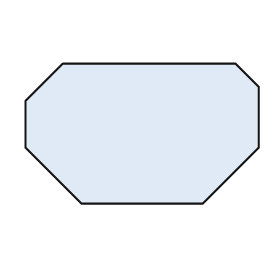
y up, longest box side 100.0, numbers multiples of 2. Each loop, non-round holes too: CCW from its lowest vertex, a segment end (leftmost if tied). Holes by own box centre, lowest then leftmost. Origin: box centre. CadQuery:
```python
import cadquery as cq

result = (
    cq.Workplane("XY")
    .moveTo(-26.0, -30.0)
    .lineTo(26.0, -30.0)
    .lineTo(50.0, -6.0)
    .lineTo(50.0, 20.0)
    .lineTo(40.0, 30.0)
    .lineTo(-34.0, 30.0)
    .lineTo(-50.0, 14.0)
    .lineTo(-50.0, -6.0)
    .close()
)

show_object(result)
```